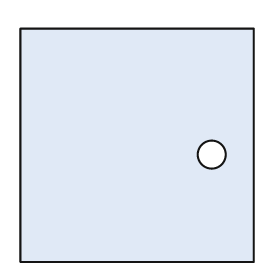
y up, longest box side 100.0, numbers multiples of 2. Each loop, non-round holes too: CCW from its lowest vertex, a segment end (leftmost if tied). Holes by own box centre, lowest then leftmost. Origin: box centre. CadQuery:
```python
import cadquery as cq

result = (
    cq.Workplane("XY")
    .moveTo(-50.0, -50.0)
    .lineTo(50.0, -50.0)
    .lineTo(50.0, 50.0)
    .lineTo(-50.0, 50.0)
    .close()
    .moveTo(32.0, -4.0)
    .circle(6.0)
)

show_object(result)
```